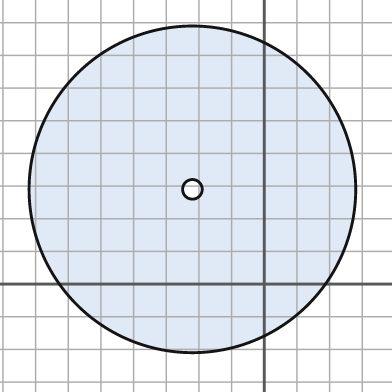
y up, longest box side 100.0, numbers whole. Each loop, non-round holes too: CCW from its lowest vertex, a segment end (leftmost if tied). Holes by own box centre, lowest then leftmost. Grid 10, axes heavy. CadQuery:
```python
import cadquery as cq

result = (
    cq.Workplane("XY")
    .moveTo(-22.0, 29.0)
    .circle(50.0)
    .moveTo(-22.0, 29.0)
    .circle(3.0)
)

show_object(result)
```